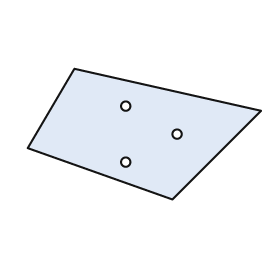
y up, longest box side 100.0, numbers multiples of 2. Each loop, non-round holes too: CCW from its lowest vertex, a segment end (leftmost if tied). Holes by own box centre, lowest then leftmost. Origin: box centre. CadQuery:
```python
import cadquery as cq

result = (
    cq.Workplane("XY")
    .moveTo(12.0, -28.0)
    .lineTo(50.0, 10.0)
    .lineTo(-30.0, 28.0)
    .lineTo(-50.0, -6.0)
    .close()
    .moveTo(-8.0, -12.0)
    .circle(2.0)
    .moveTo(14.0, 0.0)
    .circle(2.0)
    .moveTo(-8.0, 12.0)
    .circle(2.0)
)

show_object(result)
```